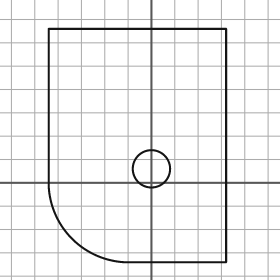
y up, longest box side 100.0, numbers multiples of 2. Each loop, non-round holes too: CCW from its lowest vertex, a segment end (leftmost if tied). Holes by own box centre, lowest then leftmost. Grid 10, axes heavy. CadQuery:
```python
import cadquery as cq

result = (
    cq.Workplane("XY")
    .moveTo(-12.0, -34.0)
    .lineTo(32.0, -34.0)
    .lineTo(32.0, 66.0)
    .lineTo(-44.0, 66.0)
    .lineTo(-44.0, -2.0)
    .threePointArc((-34.0, -24.0), (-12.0, -34.0))
    .close()
    .moveTo(0.0, 6.0)
    .circle(8.0)
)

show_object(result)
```